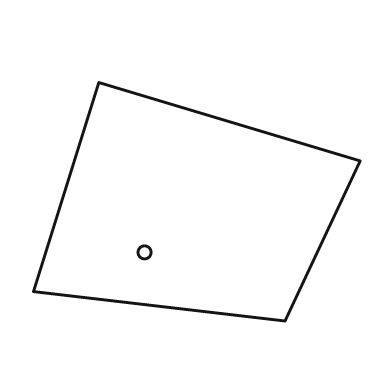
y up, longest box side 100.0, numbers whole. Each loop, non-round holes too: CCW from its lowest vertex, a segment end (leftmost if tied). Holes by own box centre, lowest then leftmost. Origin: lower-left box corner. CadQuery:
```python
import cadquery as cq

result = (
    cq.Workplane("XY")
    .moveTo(77.0, 0.0)
    .lineTo(100.0, 49.0)
    .lineTo(20.0, 73.0)
    .lineTo(0.0, 9.0)
    .close()
    .moveTo(34.0, 21.0)
    .circle(2.0)
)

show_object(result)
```